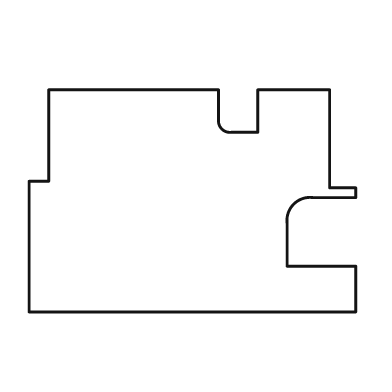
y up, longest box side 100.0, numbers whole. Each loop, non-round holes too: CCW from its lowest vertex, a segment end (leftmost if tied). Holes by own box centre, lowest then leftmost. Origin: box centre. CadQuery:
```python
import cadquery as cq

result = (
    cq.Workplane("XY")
    .moveTo(-50.0, -34.0)
    .lineTo(50.0, -34.0)
    .lineTo(50.0, -20.0)
    .lineTo(29.0, -20.0)
    .lineTo(29.0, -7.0)
    .threePointArc((31.0, -1.0), (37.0, 1.0))
    .lineTo(50.0, 1.0)
    .lineTo(50.0, 4.0)
    .lineTo(42.0, 4.0)
    .lineTo(42.0, 34.0)
    .lineTo(20.0, 34.0)
    .lineTo(20.0, 21.0)
    .lineTo(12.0, 21.0)
    .threePointArc((9.0, 22.0), (8.0, 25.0))
    .lineTo(8.0, 34.0)
    .lineTo(-44.0, 34.0)
    .lineTo(-44.0, 6.0)
    .lineTo(-50.0, 6.0)
    .close()
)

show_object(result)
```